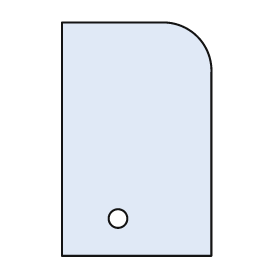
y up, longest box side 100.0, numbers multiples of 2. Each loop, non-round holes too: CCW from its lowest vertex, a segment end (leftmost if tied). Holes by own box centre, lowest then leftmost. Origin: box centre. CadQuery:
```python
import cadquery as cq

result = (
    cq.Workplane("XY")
    .moveTo(-32.0, -50.0)
    .lineTo(32.0, -50.0)
    .lineTo(32.0, 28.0)
    .threePointArc((26.0, 44.0), (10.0, 50.0))
    .lineTo(-32.0, 50.0)
    .close()
    .moveTo(-8.0, -34.0)
    .circle(4.0)
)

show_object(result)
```